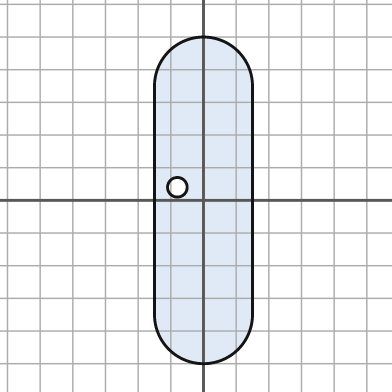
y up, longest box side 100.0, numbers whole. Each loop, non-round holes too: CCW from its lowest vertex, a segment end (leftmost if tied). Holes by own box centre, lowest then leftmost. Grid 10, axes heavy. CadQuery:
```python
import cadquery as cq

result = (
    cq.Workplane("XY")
    .moveTo(-15.0, -35.0)
    .threePointArc((0.0, -50.0), (15.0, -35.0))
    .lineTo(15.0, 35.0)
    .threePointArc((0.0, 50.0), (-15.0, 35.0))
    .close()
    .moveTo(-8.0, 4.0)
    .circle(3.0)
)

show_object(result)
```